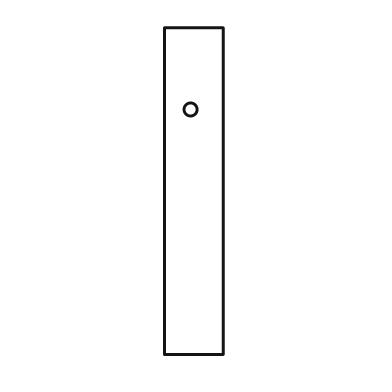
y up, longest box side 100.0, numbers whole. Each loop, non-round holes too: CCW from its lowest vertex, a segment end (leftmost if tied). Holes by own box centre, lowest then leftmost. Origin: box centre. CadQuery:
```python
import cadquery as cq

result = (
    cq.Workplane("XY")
    .moveTo(-9.0, -50.0)
    .lineTo(9.0, -50.0)
    .lineTo(9.0, 50.0)
    .lineTo(-9.0, 50.0)
    .close()
    .moveTo(-1.0, 25.0)
    .circle(2.0)
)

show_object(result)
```